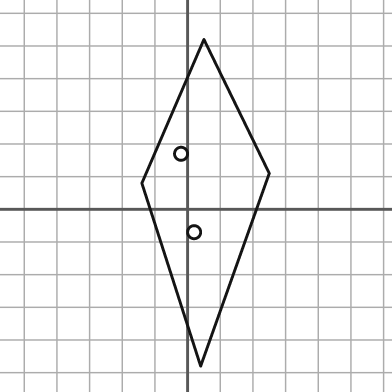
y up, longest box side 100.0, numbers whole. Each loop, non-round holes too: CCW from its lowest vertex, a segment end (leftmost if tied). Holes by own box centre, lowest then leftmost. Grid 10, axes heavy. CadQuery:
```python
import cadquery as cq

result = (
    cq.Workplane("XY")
    .moveTo(4.0, -48.0)
    .lineTo(25.0, 11.0)
    .lineTo(5.0, 52.0)
    .lineTo(-14.0, 8.0)
    .close()
    .moveTo(2.0, -7.0)
    .circle(2.0)
    .moveTo(-2.0, 17.0)
    .circle(2.0)
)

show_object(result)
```